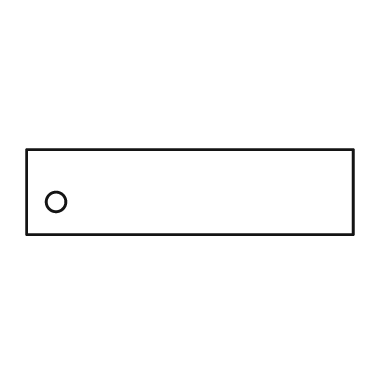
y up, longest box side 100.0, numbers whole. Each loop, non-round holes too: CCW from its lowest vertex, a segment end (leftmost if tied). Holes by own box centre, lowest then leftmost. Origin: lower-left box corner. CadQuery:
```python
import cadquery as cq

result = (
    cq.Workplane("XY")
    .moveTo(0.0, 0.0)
    .lineTo(100.0, 0.0)
    .lineTo(100.0, 26.0)
    .lineTo(0.0, 26.0)
    .close()
    .moveTo(9.0, 10.0)
    .circle(3.0)
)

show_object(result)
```